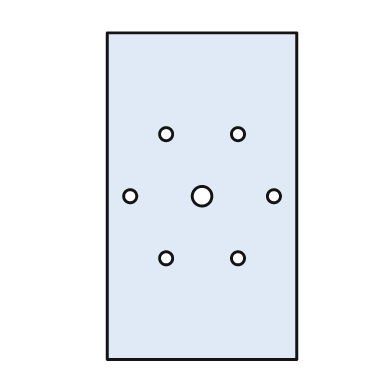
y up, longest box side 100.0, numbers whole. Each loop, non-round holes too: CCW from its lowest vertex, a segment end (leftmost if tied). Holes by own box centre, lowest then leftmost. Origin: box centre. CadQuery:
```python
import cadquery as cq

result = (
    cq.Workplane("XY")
    .moveTo(-29.0, -50.0)
    .lineTo(29.0, -50.0)
    .lineTo(29.0, 50.0)
    .lineTo(-29.0, 50.0)
    .close()
    .moveTo(-11.0, -19.0)
    .circle(2.0)
    .moveTo(11.0, -19.0)
    .circle(2.0)
    .moveTo(-22.0, 0.0)
    .circle(2.0)
    .moveTo(0.0, 0.0)
    .circle(3.0)
    .moveTo(22.0, 0.0)
    .circle(2.0)
    .moveTo(-11.0, 19.0)
    .circle(2.0)
    .moveTo(11.0, 19.0)
    .circle(2.0)
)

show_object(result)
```